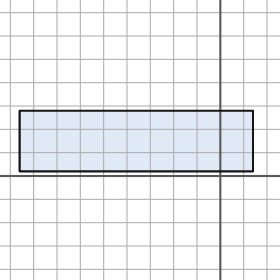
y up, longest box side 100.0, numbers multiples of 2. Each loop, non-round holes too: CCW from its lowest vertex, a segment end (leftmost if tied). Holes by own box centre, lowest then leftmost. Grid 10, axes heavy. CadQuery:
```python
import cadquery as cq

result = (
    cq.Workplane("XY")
    .moveTo(-86.0, 2.0)
    .lineTo(14.0, 2.0)
    .lineTo(14.0, 28.0)
    .lineTo(-86.0, 28.0)
    .close()
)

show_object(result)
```